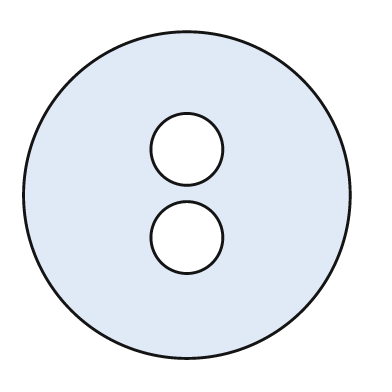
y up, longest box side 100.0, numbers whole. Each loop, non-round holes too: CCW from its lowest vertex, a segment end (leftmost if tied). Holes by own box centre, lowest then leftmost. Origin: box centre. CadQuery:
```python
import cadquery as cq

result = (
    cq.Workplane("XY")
    .moveTo(0.0, 0.0)
    .circle(50.0)
    .moveTo(0.0, -13.0)
    .circle(11.0)
    .moveTo(0.0, 14.0)
    .circle(11.0)
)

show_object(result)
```